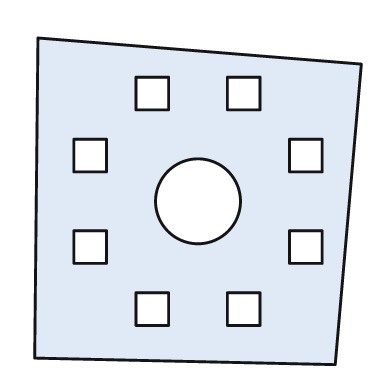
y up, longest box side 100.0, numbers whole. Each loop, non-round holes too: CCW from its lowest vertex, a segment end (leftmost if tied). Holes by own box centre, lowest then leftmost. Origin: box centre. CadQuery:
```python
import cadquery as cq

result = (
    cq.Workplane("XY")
    .moveTo(42.0, -50.0)
    .lineTo(50.0, 42.0)
    .lineTo(-49.0, 50.0)
    .lineTo(-50.0, -48.0)
    .close()
    .moveTo(-19.0, -38.0)
    .lineTo(-9.0, -38.0)
    .lineTo(-9.0, -28.0)
    .lineTo(-19.0, -28.0)
    .close()
    .moveTo(9.0, -38.0)
    .lineTo(19.0, -38.0)
    .lineTo(19.0, -28.0)
    .lineTo(9.0, -28.0)
    .close()
    .moveTo(-38.0, -19.0)
    .lineTo(-28.0, -19.0)
    .lineTo(-28.0, -9.0)
    .lineTo(-38.0, -9.0)
    .close()
    .moveTo(28.0, -19.0)
    .lineTo(38.0, -19.0)
    .lineTo(38.0, -9.0)
    .lineTo(28.0, -9.0)
    .close()
    .moveTo(0.0, 0.0)
    .circle(13.0)
    .moveTo(-38.0, 9.0)
    .lineTo(-28.0, 9.0)
    .lineTo(-28.0, 19.0)
    .lineTo(-38.0, 19.0)
    .close()
    .moveTo(28.0, 9.0)
    .lineTo(38.0, 9.0)
    .lineTo(38.0, 19.0)
    .lineTo(28.0, 19.0)
    .close()
    .moveTo(-19.0, 28.0)
    .lineTo(-9.0, 28.0)
    .lineTo(-9.0, 38.0)
    .lineTo(-19.0, 38.0)
    .close()
    .moveTo(9.0, 28.0)
    .lineTo(19.0, 28.0)
    .lineTo(19.0, 38.0)
    .lineTo(9.0, 38.0)
    .close()
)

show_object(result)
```